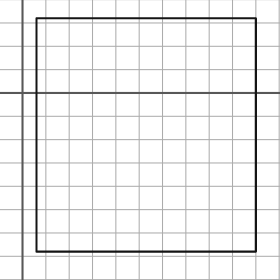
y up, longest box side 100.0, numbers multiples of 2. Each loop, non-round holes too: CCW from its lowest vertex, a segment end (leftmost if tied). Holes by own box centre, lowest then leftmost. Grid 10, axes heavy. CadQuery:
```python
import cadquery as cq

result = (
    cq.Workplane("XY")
    .moveTo(6.0, -68.0)
    .lineTo(100.0, -68.0)
    .lineTo(100.0, 32.0)
    .lineTo(6.0, 32.0)
    .close()
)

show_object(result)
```